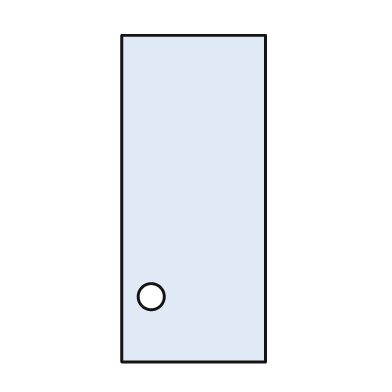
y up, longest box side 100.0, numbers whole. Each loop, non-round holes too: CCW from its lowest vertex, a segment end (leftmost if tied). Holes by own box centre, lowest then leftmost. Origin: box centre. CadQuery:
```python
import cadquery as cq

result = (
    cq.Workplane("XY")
    .moveTo(-22.0, -50.0)
    .lineTo(22.0, -50.0)
    .lineTo(22.0, 50.0)
    .lineTo(-22.0, 50.0)
    .close()
    .moveTo(-13.0, -30.0)
    .circle(4.0)
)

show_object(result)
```